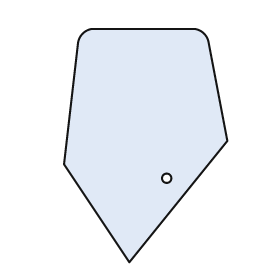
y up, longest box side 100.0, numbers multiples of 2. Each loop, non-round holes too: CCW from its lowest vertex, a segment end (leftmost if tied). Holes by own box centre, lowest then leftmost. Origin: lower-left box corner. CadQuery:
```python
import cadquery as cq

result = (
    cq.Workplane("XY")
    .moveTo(28.0, 0.0)
    .lineTo(70.0, 52.0)
    .lineTo(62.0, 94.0)
    .threePointArc((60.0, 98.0), (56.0, 100.0))
    .lineTo(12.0, 100.0)
    .threePointArc((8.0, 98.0), (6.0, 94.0))
    .lineTo(0.0, 42.0)
    .close()
    .moveTo(44.0, 36.0)
    .circle(2.0)
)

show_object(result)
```